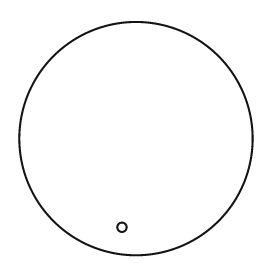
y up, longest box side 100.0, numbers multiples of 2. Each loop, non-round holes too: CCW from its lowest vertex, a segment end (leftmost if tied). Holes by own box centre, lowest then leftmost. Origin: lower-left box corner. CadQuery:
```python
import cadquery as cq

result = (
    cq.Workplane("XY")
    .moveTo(50.0, 50.0)
    .circle(50.0)
    .moveTo(44.0, 12.0)
    .circle(2.0)
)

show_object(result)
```